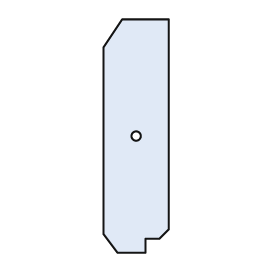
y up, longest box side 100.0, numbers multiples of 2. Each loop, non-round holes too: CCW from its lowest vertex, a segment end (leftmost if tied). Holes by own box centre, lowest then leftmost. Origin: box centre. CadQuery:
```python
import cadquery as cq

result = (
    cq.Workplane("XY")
    .moveTo(-8.0, -50.0)
    .lineTo(4.0, -50.0)
    .lineTo(4.0, -44.0)
    .lineTo(10.0, -44.0)
    .lineTo(14.0, -40.0)
    .lineTo(14.0, 50.0)
    .lineTo(-6.0, 50.0)
    .lineTo(-14.0, 38.0)
    .lineTo(-14.0, -42.0)
    .close()
    .moveTo(0.0, 0.0)
    .circle(2.0)
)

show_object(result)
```